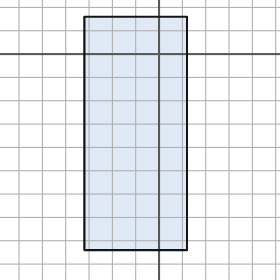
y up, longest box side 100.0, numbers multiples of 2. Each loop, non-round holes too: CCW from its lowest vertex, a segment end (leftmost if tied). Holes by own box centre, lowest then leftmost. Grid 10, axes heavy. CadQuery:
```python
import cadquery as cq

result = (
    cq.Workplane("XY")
    .moveTo(-32.0, -84.0)
    .lineTo(12.0, -84.0)
    .lineTo(12.0, 16.0)
    .lineTo(-32.0, 16.0)
    .close()
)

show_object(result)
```